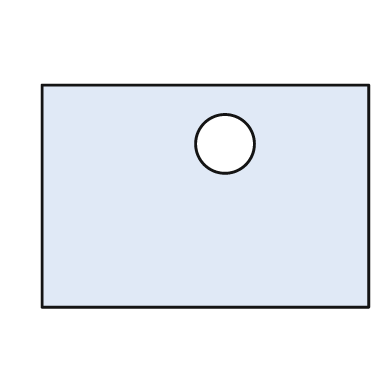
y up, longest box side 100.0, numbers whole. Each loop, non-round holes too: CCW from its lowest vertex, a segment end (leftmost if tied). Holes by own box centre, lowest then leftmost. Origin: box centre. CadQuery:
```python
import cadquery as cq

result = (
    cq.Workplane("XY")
    .moveTo(-50.0, -34.0)
    .lineTo(50.0, -34.0)
    .lineTo(50.0, 34.0)
    .lineTo(-50.0, 34.0)
    .close()
    .moveTo(6.0, 16.0)
    .circle(9.0)
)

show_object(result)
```